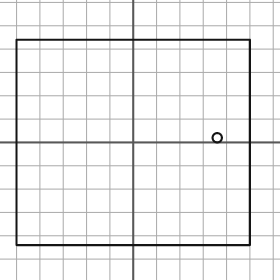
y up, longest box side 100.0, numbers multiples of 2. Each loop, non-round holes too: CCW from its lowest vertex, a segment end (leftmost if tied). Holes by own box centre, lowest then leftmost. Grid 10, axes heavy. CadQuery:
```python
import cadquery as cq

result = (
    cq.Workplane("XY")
    .moveTo(-50.0, -44.0)
    .lineTo(50.0, -44.0)
    .lineTo(50.0, 44.0)
    .lineTo(-50.0, 44.0)
    .close()
    .moveTo(36.0, 2.0)
    .circle(2.0)
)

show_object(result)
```